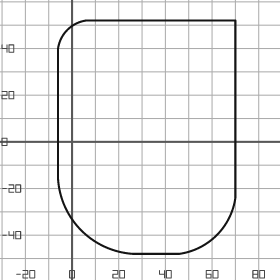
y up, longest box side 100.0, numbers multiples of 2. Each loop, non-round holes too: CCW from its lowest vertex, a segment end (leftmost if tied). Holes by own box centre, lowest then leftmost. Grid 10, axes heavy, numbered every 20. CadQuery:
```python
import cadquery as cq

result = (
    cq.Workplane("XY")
    .moveTo(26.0, -48.0)
    .lineTo(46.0, -48.0)
    .threePointArc((62.0, -40.0), (70.0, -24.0))
    .lineTo(70.0, 52.0)
    .lineTo(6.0, 52.0)
    .threePointArc((-2.0, 48.0), (-6.0, 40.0))
    .lineTo(-6.0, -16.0)
    .threePointArc((4.0, -38.0), (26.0, -48.0))
    .close()
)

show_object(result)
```